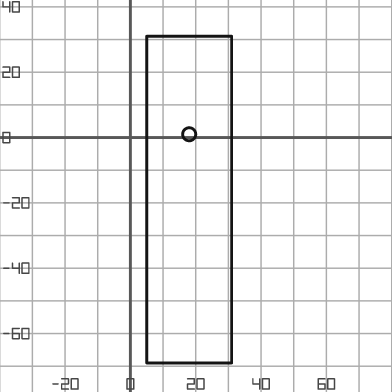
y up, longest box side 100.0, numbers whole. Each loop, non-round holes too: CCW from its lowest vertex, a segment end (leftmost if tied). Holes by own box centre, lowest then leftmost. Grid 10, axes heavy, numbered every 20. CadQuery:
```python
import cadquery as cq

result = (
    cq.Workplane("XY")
    .moveTo(5.0, -69.0)
    .lineTo(31.0, -69.0)
    .lineTo(31.0, 31.0)
    .lineTo(5.0, 31.0)
    .close()
    .moveTo(18.0, 1.0)
    .circle(2.0)
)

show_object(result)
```